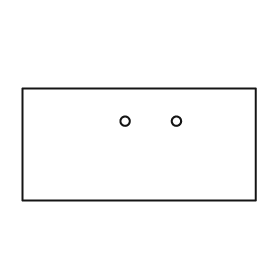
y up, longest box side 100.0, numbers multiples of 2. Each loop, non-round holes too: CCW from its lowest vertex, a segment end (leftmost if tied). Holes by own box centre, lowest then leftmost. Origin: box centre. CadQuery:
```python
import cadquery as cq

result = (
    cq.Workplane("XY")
    .moveTo(-50.0, -24.0)
    .lineTo(50.0, -24.0)
    .lineTo(50.0, 24.0)
    .lineTo(-50.0, 24.0)
    .close()
    .moveTo(-6.0, 10.0)
    .circle(2.0)
    .moveTo(16.0, 10.0)
    .circle(2.0)
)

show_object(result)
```